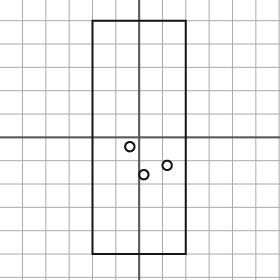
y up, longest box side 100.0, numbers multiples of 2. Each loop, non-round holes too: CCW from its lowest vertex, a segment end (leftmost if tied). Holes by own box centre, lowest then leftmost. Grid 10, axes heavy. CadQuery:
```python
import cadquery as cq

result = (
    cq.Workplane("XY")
    .moveTo(-20.0, -50.0)
    .lineTo(20.0, -50.0)
    .lineTo(20.0, 50.0)
    .lineTo(-20.0, 50.0)
    .close()
    .moveTo(2.0, -16.0)
    .circle(2.0)
    .moveTo(12.0, -12.0)
    .circle(2.0)
    .moveTo(-4.0, -4.0)
    .circle(2.0)
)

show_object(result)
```